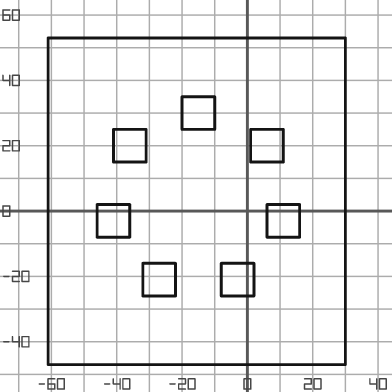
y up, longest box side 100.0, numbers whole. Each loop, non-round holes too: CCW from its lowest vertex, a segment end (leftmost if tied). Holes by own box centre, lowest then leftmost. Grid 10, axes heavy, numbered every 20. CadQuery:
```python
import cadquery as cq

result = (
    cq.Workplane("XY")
    .moveTo(-61.0, -47.0)
    .lineTo(30.0, -47.0)
    .lineTo(30.0, 53.0)
    .lineTo(-61.0, 53.0)
    .close()
    .moveTo(-32.0, -26.0)
    .lineTo(-22.0, -26.0)
    .lineTo(-22.0, -16.0)
    .lineTo(-32.0, -16.0)
    .close()
    .moveTo(-8.0, -26.0)
    .lineTo(2.0, -26.0)
    .lineTo(2.0, -16.0)
    .lineTo(-8.0, -16.0)
    .close()
    .moveTo(-46.0, -8.0)
    .lineTo(-36.0, -8.0)
    .lineTo(-36.0, 2.0)
    .lineTo(-46.0, 2.0)
    .close()
    .moveTo(6.0, -8.0)
    .lineTo(16.0, -8.0)
    .lineTo(16.0, 2.0)
    .lineTo(6.0, 2.0)
    .close()
    .moveTo(-41.0, 15.0)
    .lineTo(-31.0, 15.0)
    .lineTo(-31.0, 25.0)
    .lineTo(-41.0, 25.0)
    .close()
    .moveTo(1.0, 15.0)
    .lineTo(11.0, 15.0)
    .lineTo(11.0, 25.0)
    .lineTo(1.0, 25.0)
    .close()
    .moveTo(-20.0, 25.0)
    .lineTo(-10.0, 25.0)
    .lineTo(-10.0, 35.0)
    .lineTo(-20.0, 35.0)
    .close()
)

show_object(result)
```